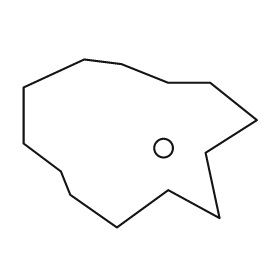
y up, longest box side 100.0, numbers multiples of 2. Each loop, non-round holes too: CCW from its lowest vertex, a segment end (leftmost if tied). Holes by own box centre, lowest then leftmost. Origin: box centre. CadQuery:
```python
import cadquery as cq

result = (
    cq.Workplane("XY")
    .moveTo(-10.0, -36.0)
    .lineTo(12.0, -20.0)
    .lineTo(34.0, -32.0)
    .lineTo(28.0, -4.0)
    .lineTo(50.0, 10.0)
    .lineTo(30.0, 26.0)
    .lineTo(12.0, 26.0)
    .lineTo(-8.0, 34.0)
    .lineTo(-24.0, 36.0)
    .lineTo(-50.0, 24.0)
    .lineTo(-50.0, 0.0)
    .lineTo(-34.0, -12.0)
    .lineTo(-30.0, -22.0)
    .close()
    .moveTo(10.0, -2.0)
    .circle(4.0)
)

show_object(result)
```